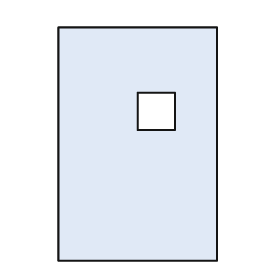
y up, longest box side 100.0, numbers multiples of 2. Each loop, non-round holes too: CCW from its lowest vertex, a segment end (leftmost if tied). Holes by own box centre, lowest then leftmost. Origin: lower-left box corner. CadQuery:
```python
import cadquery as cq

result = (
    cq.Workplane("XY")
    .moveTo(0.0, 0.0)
    .lineTo(68.0, 0.0)
    .lineTo(68.0, 100.0)
    .lineTo(0.0, 100.0)
    .close()
    .moveTo(34.0, 56.0)
    .lineTo(50.0, 56.0)
    .lineTo(50.0, 72.0)
    .lineTo(34.0, 72.0)
    .close()
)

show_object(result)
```